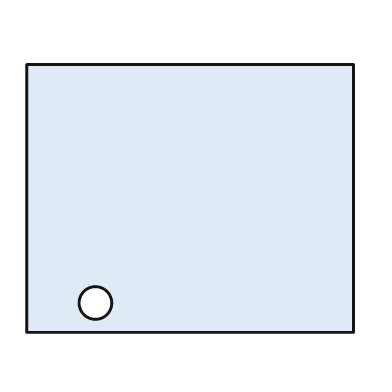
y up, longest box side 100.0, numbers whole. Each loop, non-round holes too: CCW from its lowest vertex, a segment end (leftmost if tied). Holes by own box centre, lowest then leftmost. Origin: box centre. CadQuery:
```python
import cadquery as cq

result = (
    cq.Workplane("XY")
    .moveTo(-50.0, -41.0)
    .lineTo(50.0, -41.0)
    .lineTo(50.0, 41.0)
    .lineTo(-50.0, 41.0)
    .close()
    .moveTo(-29.0, -32.0)
    .circle(5.0)
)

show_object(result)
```